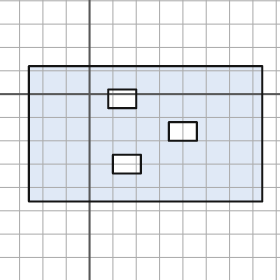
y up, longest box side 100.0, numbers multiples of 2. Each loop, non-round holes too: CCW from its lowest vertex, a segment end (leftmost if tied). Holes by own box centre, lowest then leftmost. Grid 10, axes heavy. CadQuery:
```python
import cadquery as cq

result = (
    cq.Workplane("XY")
    .moveTo(-26.0, -46.0)
    .lineTo(74.0, -46.0)
    .lineTo(74.0, 12.0)
    .lineTo(-26.0, 12.0)
    .close()
    .moveTo(10.0, -34.0)
    .lineTo(22.0, -34.0)
    .lineTo(22.0, -26.0)
    .lineTo(10.0, -26.0)
    .close()
    .moveTo(34.0, -20.0)
    .lineTo(46.0, -20.0)
    .lineTo(46.0, -12.0)
    .lineTo(34.0, -12.0)
    .close()
    .moveTo(8.0, -6.0)
    .lineTo(20.0, -6.0)
    .lineTo(20.0, 2.0)
    .lineTo(8.0, 2.0)
    .close()
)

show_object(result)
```